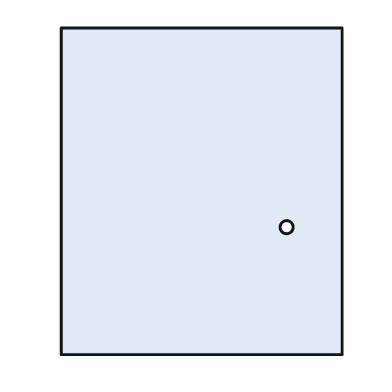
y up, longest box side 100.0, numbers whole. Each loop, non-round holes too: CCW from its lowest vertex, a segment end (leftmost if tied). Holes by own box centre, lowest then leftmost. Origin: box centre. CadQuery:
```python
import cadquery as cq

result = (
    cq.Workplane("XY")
    .moveTo(-43.0, -50.0)
    .lineTo(43.0, -50.0)
    .lineTo(43.0, 50.0)
    .lineTo(-43.0, 50.0)
    .close()
    .moveTo(26.0, -11.0)
    .circle(2.0)
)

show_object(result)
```